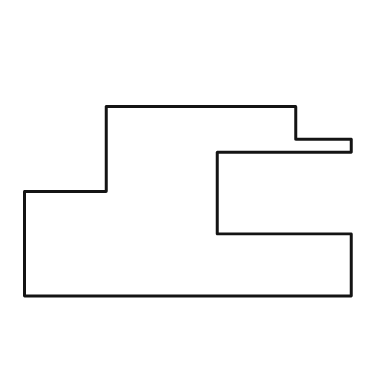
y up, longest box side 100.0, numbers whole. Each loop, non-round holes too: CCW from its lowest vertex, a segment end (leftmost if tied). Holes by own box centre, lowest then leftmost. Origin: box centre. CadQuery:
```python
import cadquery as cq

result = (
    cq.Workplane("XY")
    .moveTo(-50.0, -29.0)
    .lineTo(50.0, -29.0)
    .lineTo(50.0, -10.0)
    .lineTo(9.0, -10.0)
    .lineTo(9.0, 15.0)
    .lineTo(50.0, 15.0)
    .lineTo(50.0, 19.0)
    .lineTo(33.0, 19.0)
    .lineTo(33.0, 29.0)
    .lineTo(-25.0, 29.0)
    .lineTo(-25.0, 3.0)
    .lineTo(-50.0, 3.0)
    .close()
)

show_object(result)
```